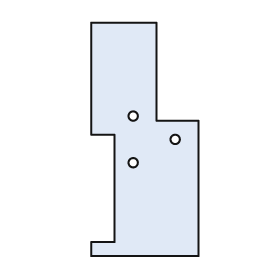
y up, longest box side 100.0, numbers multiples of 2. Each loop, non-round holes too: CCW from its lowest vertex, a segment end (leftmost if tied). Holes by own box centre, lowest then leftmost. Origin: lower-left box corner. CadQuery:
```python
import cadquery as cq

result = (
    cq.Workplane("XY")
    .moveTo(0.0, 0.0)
    .lineTo(46.0, 0.0)
    .lineTo(46.0, 58.0)
    .lineTo(28.0, 58.0)
    .lineTo(28.0, 100.0)
    .lineTo(0.0, 100.0)
    .lineTo(0.0, 52.0)
    .lineTo(10.0, 52.0)
    .lineTo(10.0, 6.0)
    .lineTo(0.0, 6.0)
    .close()
    .moveTo(18.0, 40.0)
    .circle(2.0)
    .moveTo(36.0, 50.0)
    .circle(2.0)
    .moveTo(18.0, 60.0)
    .circle(2.0)
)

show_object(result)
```